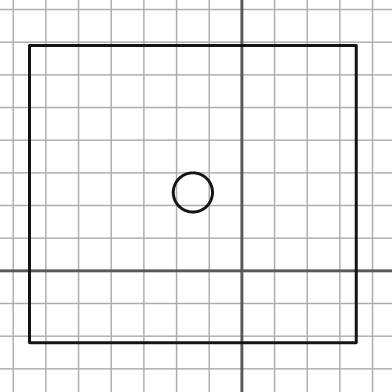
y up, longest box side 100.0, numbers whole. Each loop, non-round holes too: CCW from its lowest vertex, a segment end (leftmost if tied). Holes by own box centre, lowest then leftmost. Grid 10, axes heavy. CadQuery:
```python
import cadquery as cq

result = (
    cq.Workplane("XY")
    .moveTo(-65.0, -22.0)
    .lineTo(35.0, -22.0)
    .lineTo(35.0, 69.0)
    .lineTo(-65.0, 69.0)
    .close()
    .moveTo(-15.0, 24.0)
    .circle(6.0)
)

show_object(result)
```